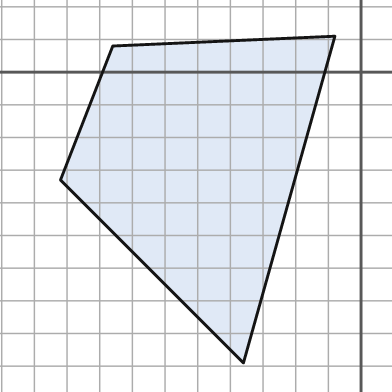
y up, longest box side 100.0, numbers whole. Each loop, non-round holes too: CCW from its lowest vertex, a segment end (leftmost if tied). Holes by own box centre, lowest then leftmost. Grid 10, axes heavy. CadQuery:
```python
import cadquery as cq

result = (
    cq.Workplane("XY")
    .moveTo(-36.0, -89.0)
    .lineTo(-8.0, 11.0)
    .lineTo(-76.0, 8.0)
    .lineTo(-92.0, -33.0)
    .close()
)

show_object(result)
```